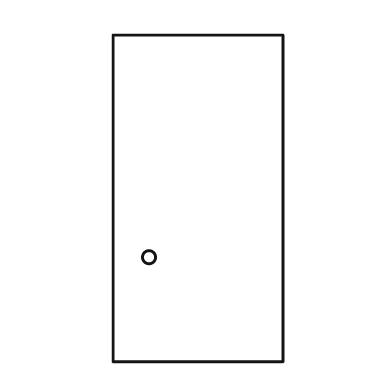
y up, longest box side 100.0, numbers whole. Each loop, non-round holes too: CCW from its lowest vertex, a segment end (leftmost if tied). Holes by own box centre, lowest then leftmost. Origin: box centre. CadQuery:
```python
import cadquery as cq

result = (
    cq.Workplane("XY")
    .moveTo(-26.0, -50.0)
    .lineTo(26.0, -50.0)
    .lineTo(26.0, 50.0)
    .lineTo(-26.0, 50.0)
    .close()
    .moveTo(-15.0, -18.0)
    .circle(2.0)
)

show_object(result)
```